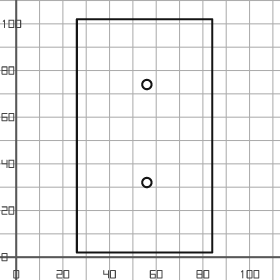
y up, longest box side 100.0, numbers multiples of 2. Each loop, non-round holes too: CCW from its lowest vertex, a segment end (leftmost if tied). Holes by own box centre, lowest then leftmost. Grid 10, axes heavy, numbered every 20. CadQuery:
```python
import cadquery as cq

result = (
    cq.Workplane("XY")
    .moveTo(26.0, 2.0)
    .lineTo(84.0, 2.0)
    .lineTo(84.0, 102.0)
    .lineTo(26.0, 102.0)
    .close()
    .moveTo(56.0, 32.0)
    .circle(2.0)
    .moveTo(56.0, 74.0)
    .circle(2.0)
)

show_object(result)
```